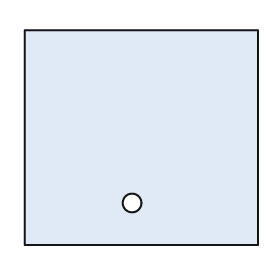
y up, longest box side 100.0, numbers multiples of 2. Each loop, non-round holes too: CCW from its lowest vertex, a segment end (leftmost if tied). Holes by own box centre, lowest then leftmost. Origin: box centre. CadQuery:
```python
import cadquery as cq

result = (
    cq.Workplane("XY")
    .moveTo(-50.0, -46.0)
    .lineTo(50.0, -46.0)
    .lineTo(50.0, 46.0)
    .lineTo(-50.0, 46.0)
    .close()
    .moveTo(-4.0, -28.0)
    .circle(4.0)
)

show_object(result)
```